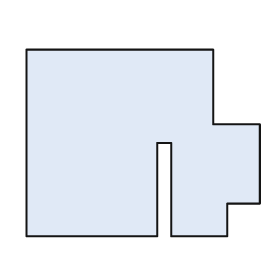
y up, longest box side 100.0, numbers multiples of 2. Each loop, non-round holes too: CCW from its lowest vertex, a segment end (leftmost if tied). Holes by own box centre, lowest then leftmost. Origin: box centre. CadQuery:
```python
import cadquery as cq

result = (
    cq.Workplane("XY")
    .moveTo(-50.0, -40.0)
    .lineTo(6.0, -40.0)
    .lineTo(6.0, 0.0)
    .lineTo(12.0, 0.0)
    .lineTo(12.0, -40.0)
    .lineTo(36.0, -40.0)
    .lineTo(36.0, -26.0)
    .lineTo(50.0, -26.0)
    .lineTo(50.0, 8.0)
    .lineTo(30.0, 8.0)
    .lineTo(30.0, 40.0)
    .lineTo(-50.0, 40.0)
    .close()
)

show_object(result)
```